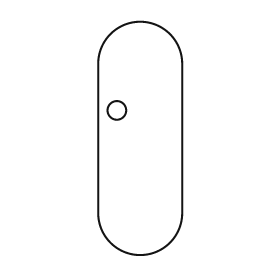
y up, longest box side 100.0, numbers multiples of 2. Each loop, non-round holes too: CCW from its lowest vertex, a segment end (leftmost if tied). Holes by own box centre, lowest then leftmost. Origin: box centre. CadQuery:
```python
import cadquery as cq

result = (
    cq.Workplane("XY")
    .moveTo(-18.0, -32.0)
    .threePointArc((0.0, -50.0), (18.0, -32.0))
    .lineTo(18.0, 32.0)
    .threePointArc((0.0, 50.0), (-18.0, 32.0))
    .close()
    .moveTo(-10.0, 12.0)
    .circle(4.0)
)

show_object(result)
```